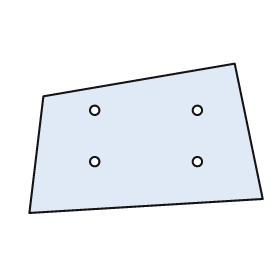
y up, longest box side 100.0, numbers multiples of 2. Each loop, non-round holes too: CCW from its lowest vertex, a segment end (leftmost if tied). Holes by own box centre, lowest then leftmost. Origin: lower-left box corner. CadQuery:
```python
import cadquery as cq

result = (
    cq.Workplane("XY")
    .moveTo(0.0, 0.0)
    .lineTo(100.0, 6.0)
    .lineTo(88.0, 64.0)
    .lineTo(6.0, 50.0)
    .close()
    .moveTo(28.0, 22.0)
    .circle(2.0)
    .moveTo(72.0, 22.0)
    .circle(2.0)
    .moveTo(28.0, 44.0)
    .circle(2.0)
    .moveTo(72.0, 44.0)
    .circle(2.0)
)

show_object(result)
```